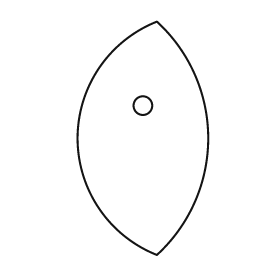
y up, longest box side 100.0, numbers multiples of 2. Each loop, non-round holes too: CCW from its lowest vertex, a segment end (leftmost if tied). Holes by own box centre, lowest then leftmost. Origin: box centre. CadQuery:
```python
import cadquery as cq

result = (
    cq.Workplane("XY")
    .moveTo(6.0, -50.0)
    .threePointArc((28.0, 0.0), (6.0, 50.0))
    .threePointArc((-28.0, 0.0), (6.0, -50.0))
    .close()
    .moveTo(0.0, 14.0)
    .circle(4.0)
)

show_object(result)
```